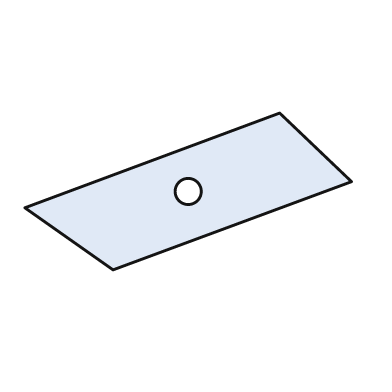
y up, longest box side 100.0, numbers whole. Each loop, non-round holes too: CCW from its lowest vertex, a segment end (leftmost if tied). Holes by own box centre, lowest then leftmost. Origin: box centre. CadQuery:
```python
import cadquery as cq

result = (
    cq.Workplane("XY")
    .moveTo(-23.0, -24.0)
    .lineTo(50.0, 3.0)
    .lineTo(28.0, 24.0)
    .lineTo(-50.0, -5.0)
    .close()
    .moveTo(0.0, 0.0)
    .circle(4.0)
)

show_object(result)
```